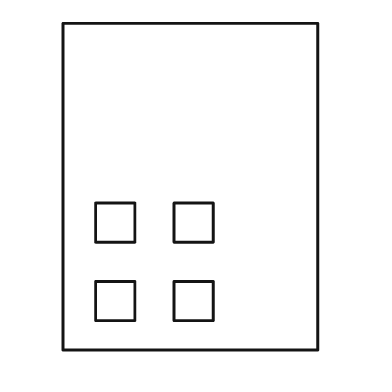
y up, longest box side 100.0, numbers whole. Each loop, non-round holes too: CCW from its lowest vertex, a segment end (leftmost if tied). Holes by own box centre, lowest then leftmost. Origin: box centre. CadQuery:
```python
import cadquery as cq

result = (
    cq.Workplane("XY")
    .moveTo(-39.0, -50.0)
    .lineTo(39.0, -50.0)
    .lineTo(39.0, 50.0)
    .lineTo(-39.0, 50.0)
    .close()
    .moveTo(-29.0, -41.0)
    .lineTo(-17.0, -41.0)
    .lineTo(-17.0, -29.0)
    .lineTo(-29.0, -29.0)
    .close()
    .moveTo(-5.0, -41.0)
    .lineTo(7.0, -41.0)
    .lineTo(7.0, -29.0)
    .lineTo(-5.0, -29.0)
    .close()
    .moveTo(-29.0, -17.0)
    .lineTo(-17.0, -17.0)
    .lineTo(-17.0, -5.0)
    .lineTo(-29.0, -5.0)
    .close()
    .moveTo(-5.0, -17.0)
    .lineTo(7.0, -17.0)
    .lineTo(7.0, -5.0)
    .lineTo(-5.0, -5.0)
    .close()
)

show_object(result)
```